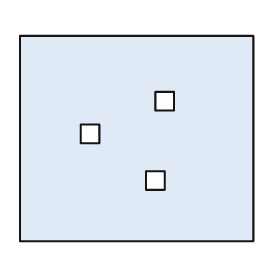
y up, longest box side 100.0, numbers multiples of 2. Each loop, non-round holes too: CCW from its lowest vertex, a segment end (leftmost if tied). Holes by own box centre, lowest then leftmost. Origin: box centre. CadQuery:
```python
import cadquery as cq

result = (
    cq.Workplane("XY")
    .moveTo(-50.0, -44.0)
    .lineTo(50.0, -44.0)
    .lineTo(50.0, 44.0)
    .lineTo(-50.0, 44.0)
    .close()
    .moveTo(4.0, -22.0)
    .lineTo(12.0, -22.0)
    .lineTo(12.0, -14.0)
    .lineTo(4.0, -14.0)
    .close()
    .moveTo(-24.0, -2.0)
    .lineTo(-16.0, -2.0)
    .lineTo(-16.0, 6.0)
    .lineTo(-24.0, 6.0)
    .close()
    .moveTo(8.0, 12.0)
    .lineTo(16.0, 12.0)
    .lineTo(16.0, 20.0)
    .lineTo(8.0, 20.0)
    .close()
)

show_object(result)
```